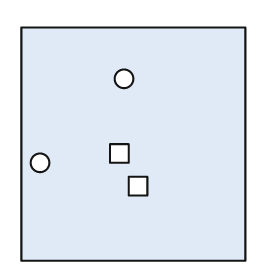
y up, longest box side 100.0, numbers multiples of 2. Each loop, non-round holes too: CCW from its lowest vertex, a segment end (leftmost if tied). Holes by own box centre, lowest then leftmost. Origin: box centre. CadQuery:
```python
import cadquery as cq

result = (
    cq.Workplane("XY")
    .moveTo(-48.0, -50.0)
    .lineTo(48.0, -50.0)
    .lineTo(48.0, 50.0)
    .lineTo(-48.0, 50.0)
    .close()
    .moveTo(-2.0, -22.0)
    .lineTo(6.0, -22.0)
    .lineTo(6.0, -14.0)
    .lineTo(-2.0, -14.0)
    .close()
    .moveTo(-40.0, -8.0)
    .circle(4.0)
    .moveTo(-10.0, -8.0)
    .lineTo(-2.0, -8.0)
    .lineTo(-2.0, 0.0)
    .lineTo(-10.0, 0.0)
    .close()
    .moveTo(-4.0, 28.0)
    .circle(4.0)
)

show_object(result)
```